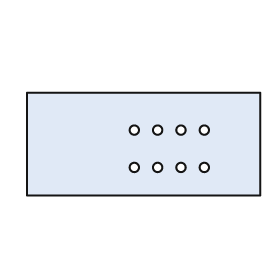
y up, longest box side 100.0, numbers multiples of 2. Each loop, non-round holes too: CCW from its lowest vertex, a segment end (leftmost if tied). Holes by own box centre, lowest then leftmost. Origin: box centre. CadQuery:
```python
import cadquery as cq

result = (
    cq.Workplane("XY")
    .moveTo(-50.0, -22.0)
    .lineTo(50.0, -22.0)
    .lineTo(50.0, 22.0)
    .lineTo(-50.0, 22.0)
    .close()
    .moveTo(-4.0, -10.0)
    .circle(2.0)
    .moveTo(6.0, -10.0)
    .circle(2.0)
    .moveTo(16.0, -10.0)
    .circle(2.0)
    .moveTo(26.0, -10.0)
    .circle(2.0)
    .moveTo(-4.0, 6.0)
    .circle(2.0)
    .moveTo(6.0, 6.0)
    .circle(2.0)
    .moveTo(16.0, 6.0)
    .circle(2.0)
    .moveTo(26.0, 6.0)
    .circle(2.0)
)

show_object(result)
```